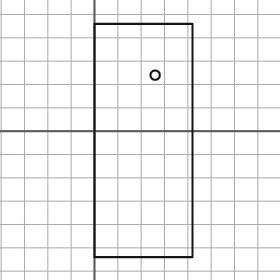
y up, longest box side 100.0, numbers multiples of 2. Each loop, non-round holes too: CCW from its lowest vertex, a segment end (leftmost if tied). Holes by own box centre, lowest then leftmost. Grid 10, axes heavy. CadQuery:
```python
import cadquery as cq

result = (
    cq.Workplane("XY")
    .moveTo(0.0, -54.0)
    .lineTo(42.0, -54.0)
    .lineTo(42.0, 46.0)
    .lineTo(0.0, 46.0)
    .close()
    .moveTo(26.0, 24.0)
    .circle(2.0)
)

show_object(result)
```